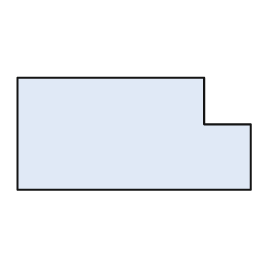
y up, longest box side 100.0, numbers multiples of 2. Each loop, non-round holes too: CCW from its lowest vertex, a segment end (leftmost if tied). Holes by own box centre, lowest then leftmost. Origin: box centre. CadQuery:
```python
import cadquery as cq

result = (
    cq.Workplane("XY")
    .moveTo(-50.0, -24.0)
    .lineTo(50.0, -24.0)
    .lineTo(50.0, 4.0)
    .lineTo(30.0, 4.0)
    .lineTo(30.0, 24.0)
    .lineTo(-50.0, 24.0)
    .close()
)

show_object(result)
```